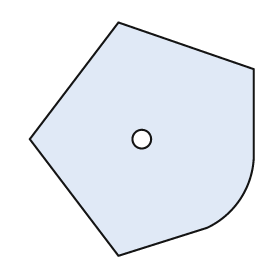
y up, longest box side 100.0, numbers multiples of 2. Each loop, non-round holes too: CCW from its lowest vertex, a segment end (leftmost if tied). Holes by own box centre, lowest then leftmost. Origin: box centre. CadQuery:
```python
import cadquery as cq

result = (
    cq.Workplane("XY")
    .moveTo(-10.0, -50.0)
    .lineTo(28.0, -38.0)
    .threePointArc((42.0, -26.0), (48.0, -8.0))
    .lineTo(48.0, 30.0)
    .lineTo(-10.0, 50.0)
    .lineTo(-48.0, 0.0)
    .close()
    .moveTo(0.0, 0.0)
    .circle(4.0)
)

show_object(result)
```